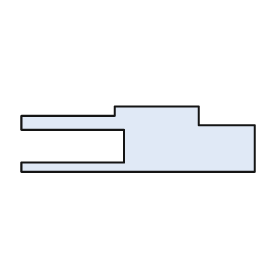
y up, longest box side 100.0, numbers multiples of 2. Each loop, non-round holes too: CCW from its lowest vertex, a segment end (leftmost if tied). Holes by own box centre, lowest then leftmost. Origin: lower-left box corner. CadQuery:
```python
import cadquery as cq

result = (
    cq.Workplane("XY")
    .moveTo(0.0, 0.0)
    .lineTo(100.0, 0.0)
    .lineTo(100.0, 20.0)
    .lineTo(76.0, 20.0)
    .lineTo(76.0, 28.0)
    .lineTo(40.0, 28.0)
    .lineTo(40.0, 24.0)
    .lineTo(0.0, 24.0)
    .lineTo(0.0, 18.0)
    .lineTo(44.0, 18.0)
    .lineTo(44.0, 4.0)
    .lineTo(0.0, 4.0)
    .close()
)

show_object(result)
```